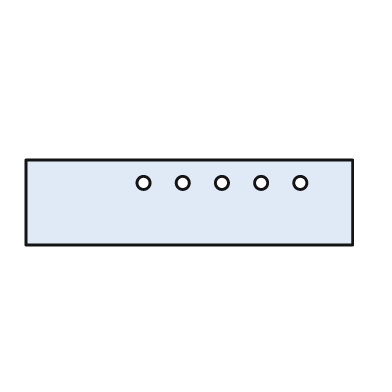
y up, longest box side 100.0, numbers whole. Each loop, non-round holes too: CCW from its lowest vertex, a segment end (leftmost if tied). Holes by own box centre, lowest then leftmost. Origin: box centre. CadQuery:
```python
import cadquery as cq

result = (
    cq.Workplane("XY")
    .moveTo(-50.0, -13.0)
    .lineTo(50.0, -13.0)
    .lineTo(50.0, 13.0)
    .lineTo(-50.0, 13.0)
    .close()
    .moveTo(-14.0, 6.0)
    .circle(2.0)
    .moveTo(-2.0, 6.0)
    .circle(2.0)
    .moveTo(10.0, 6.0)
    .circle(2.0)
    .moveTo(22.0, 6.0)
    .circle(2.0)
    .moveTo(34.0, 6.0)
    .circle(2.0)
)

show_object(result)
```